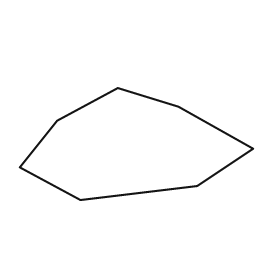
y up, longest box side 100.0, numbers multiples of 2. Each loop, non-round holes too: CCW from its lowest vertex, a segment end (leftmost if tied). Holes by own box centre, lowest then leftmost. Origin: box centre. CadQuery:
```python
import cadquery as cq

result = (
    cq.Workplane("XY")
    .moveTo(-24.0, -24.0)
    .lineTo(26.0, -18.0)
    .lineTo(50.0, -2.0)
    .lineTo(18.0, 16.0)
    .lineTo(-8.0, 24.0)
    .lineTo(-34.0, 10.0)
    .lineTo(-50.0, -10.0)
    .close()
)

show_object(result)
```